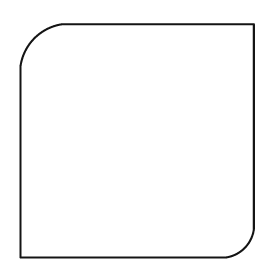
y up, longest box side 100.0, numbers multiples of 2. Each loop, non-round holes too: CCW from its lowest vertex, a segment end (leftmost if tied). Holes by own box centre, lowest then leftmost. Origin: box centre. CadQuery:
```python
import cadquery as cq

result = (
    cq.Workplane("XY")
    .moveTo(-50.0, -50.0)
    .lineTo(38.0, -50.0)
    .threePointArc((46.0, -46.0), (50.0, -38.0))
    .lineTo(50.0, 50.0)
    .lineTo(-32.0, 50.0)
    .threePointArc((-44.0, 44.0), (-50.0, 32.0))
    .close()
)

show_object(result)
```